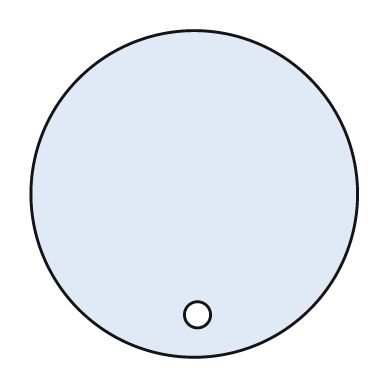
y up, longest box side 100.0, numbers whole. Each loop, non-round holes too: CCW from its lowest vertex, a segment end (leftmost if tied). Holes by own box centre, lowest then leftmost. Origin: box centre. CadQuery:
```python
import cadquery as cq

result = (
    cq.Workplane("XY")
    .moveTo(0.0, 0.0)
    .circle(50.0)
    .moveTo(1.0, -37.0)
    .circle(4.0)
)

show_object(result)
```